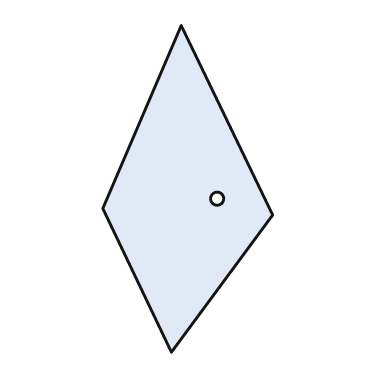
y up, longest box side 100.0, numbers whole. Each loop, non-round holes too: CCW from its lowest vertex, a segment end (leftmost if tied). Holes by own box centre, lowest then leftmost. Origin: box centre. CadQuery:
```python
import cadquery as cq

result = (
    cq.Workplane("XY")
    .moveTo(-5.0, -50.0)
    .lineTo(26.0, -8.0)
    .lineTo(-2.0, 50.0)
    .lineTo(-26.0, -6.0)
    .close()
    .moveTo(9.0, -3.0)
    .circle(2.0)
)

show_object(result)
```